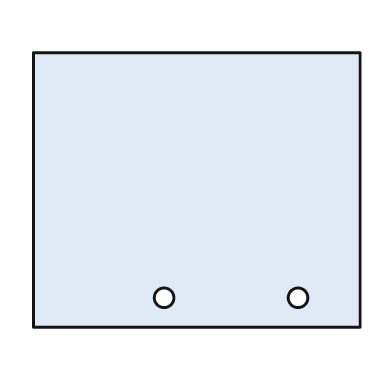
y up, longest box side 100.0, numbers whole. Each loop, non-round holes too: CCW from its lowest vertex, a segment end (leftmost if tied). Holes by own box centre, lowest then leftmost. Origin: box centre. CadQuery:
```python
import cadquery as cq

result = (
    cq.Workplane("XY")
    .moveTo(-50.0, -42.0)
    .lineTo(50.0, -42.0)
    .lineTo(50.0, 42.0)
    .lineTo(-50.0, 42.0)
    .close()
    .moveTo(-10.0, -33.0)
    .circle(3.0)
    .moveTo(31.0, -33.0)
    .circle(3.0)
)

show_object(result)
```